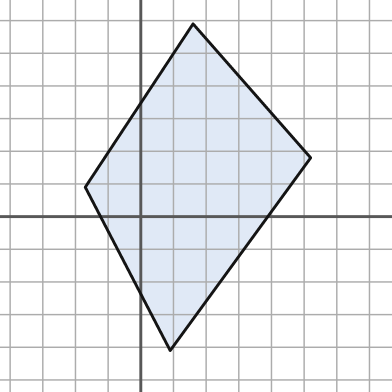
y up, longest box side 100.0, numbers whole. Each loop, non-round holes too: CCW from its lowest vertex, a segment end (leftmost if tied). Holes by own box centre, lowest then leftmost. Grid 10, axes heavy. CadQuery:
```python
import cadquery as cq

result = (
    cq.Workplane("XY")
    .moveTo(9.0, -41.0)
    .lineTo(52.0, 18.0)
    .lineTo(16.0, 59.0)
    .lineTo(-17.0, 9.0)
    .close()
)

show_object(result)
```